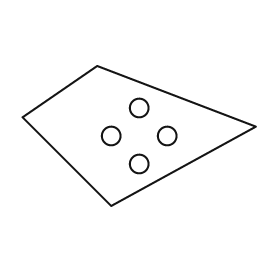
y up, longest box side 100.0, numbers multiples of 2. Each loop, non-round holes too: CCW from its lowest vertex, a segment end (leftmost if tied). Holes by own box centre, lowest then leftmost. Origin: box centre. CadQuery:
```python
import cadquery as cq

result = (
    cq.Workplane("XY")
    .moveTo(-12.0, -30.0)
    .lineTo(50.0, 4.0)
    .lineTo(-18.0, 30.0)
    .lineTo(-50.0, 8.0)
    .close()
    .moveTo(0.0, -12.0)
    .circle(4.0)
    .moveTo(-12.0, 0.0)
    .circle(4.0)
    .moveTo(12.0, 0.0)
    .circle(4.0)
    .moveTo(0.0, 12.0)
    .circle(4.0)
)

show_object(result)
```